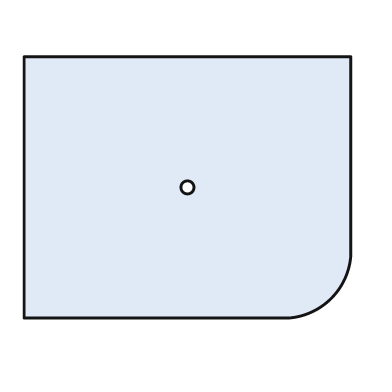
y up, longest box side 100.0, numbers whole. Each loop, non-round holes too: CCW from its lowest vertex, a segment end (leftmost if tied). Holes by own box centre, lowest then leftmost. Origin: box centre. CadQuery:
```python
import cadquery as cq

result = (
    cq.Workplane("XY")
    .moveTo(-50.0, -40.0)
    .lineTo(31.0, -40.0)
    .threePointArc((44.0, -34.0), (50.0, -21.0))
    .lineTo(50.0, 40.0)
    .lineTo(-50.0, 40.0)
    .close()
    .moveTo(0.0, 0.0)
    .circle(2.0)
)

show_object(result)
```